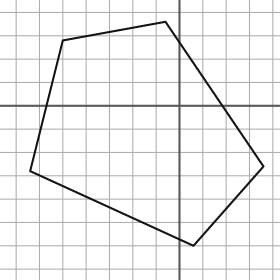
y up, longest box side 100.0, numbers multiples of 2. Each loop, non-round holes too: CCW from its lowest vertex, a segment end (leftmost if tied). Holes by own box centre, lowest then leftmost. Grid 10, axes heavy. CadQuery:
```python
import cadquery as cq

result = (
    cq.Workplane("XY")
    .moveTo(6.0, -60.0)
    .lineTo(36.0, -26.0)
    .lineTo(-6.0, 36.0)
    .lineTo(-50.0, 28.0)
    .lineTo(-64.0, -28.0)
    .close()
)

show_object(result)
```